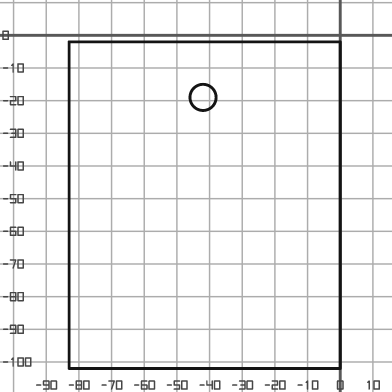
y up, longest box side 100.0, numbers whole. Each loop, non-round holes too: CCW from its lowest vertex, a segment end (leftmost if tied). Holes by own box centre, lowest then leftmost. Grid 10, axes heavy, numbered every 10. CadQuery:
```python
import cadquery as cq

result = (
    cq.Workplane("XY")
    .moveTo(-83.0, -102.0)
    .lineTo(0.0, -102.0)
    .lineTo(0.0, -2.0)
    .lineTo(-83.0, -2.0)
    .close()
    .moveTo(-42.0, -19.0)
    .circle(4.0)
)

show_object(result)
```